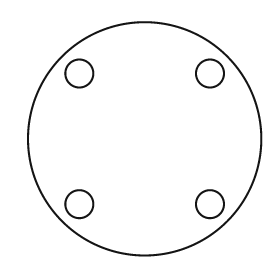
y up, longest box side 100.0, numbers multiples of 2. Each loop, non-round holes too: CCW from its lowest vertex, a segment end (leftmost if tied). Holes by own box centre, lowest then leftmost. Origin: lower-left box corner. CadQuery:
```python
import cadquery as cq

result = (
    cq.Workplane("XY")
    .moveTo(50.0, 50.0)
    .circle(50.0)
    .moveTo(22.0, 22.0)
    .circle(6.0)
    .moveTo(78.0, 22.0)
    .circle(6.0)
    .moveTo(22.0, 78.0)
    .circle(6.0)
    .moveTo(78.0, 78.0)
    .circle(6.0)
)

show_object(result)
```